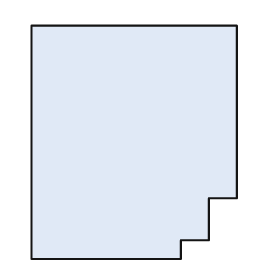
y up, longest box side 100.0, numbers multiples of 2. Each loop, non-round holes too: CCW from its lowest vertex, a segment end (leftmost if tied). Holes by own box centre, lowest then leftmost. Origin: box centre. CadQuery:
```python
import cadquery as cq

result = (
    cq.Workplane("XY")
    .moveTo(-44.0, -50.0)
    .lineTo(20.0, -50.0)
    .lineTo(20.0, -42.0)
    .lineTo(32.0, -42.0)
    .lineTo(32.0, -24.0)
    .lineTo(44.0, -24.0)
    .lineTo(44.0, 50.0)
    .lineTo(-44.0, 50.0)
    .close()
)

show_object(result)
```